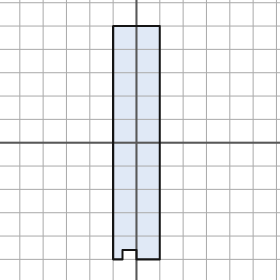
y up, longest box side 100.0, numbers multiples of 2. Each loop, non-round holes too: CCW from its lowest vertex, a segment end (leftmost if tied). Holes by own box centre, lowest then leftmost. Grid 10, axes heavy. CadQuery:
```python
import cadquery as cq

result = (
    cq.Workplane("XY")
    .moveTo(-10.0, -50.0)
    .lineTo(-6.0, -50.0)
    .lineTo(-6.0, -46.0)
    .lineTo(0.0, -46.0)
    .lineTo(0.0, -50.0)
    .lineTo(10.0, -50.0)
    .lineTo(10.0, 50.0)
    .lineTo(-10.0, 50.0)
    .close()
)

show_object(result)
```